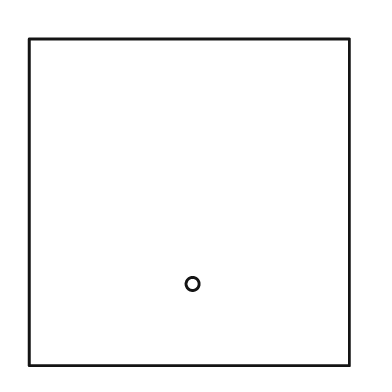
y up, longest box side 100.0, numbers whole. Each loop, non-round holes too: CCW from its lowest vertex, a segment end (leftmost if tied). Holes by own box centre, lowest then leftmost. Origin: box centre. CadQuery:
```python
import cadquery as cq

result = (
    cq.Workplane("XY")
    .moveTo(-49.0, -50.0)
    .lineTo(49.0, -50.0)
    .lineTo(49.0, 50.0)
    .lineTo(-49.0, 50.0)
    .close()
    .moveTo(1.0, -25.0)
    .circle(2.0)
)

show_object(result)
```